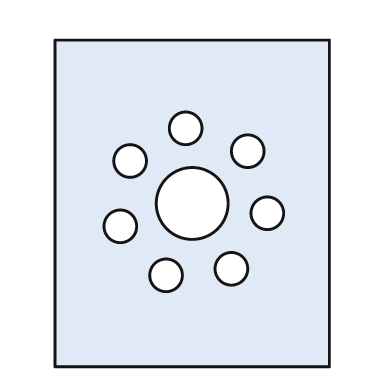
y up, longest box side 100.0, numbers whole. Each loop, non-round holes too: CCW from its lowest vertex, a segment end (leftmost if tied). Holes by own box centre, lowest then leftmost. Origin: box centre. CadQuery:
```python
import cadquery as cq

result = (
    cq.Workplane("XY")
    .moveTo(-42.0, -50.0)
    .lineTo(42.0, -50.0)
    .lineTo(42.0, 50.0)
    .lineTo(-42.0, 50.0)
    .close()
    .moveTo(-8.0, -22.0)
    .circle(5.0)
    .moveTo(12.0, -20.0)
    .circle(5.0)
    .moveTo(-22.0, -7.0)
    .circle(5.0)
    .moveTo(23.0, -3.0)
    .circle(5.0)
    .moveTo(0.0, 0.0)
    .circle(11.0)
    .moveTo(-19.0, 13.0)
    .circle(5.0)
    .moveTo(17.0, 16.0)
    .circle(5.0)
    .moveTo(-2.0, 23.0)
    .circle(5.0)
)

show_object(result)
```